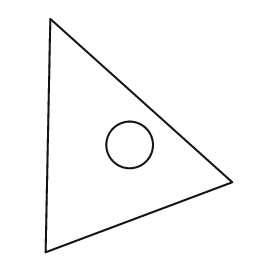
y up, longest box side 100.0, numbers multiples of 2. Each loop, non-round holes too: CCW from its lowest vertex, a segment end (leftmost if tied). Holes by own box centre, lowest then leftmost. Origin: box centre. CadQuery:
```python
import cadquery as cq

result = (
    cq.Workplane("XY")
    .moveTo(-40.0, -50.0)
    .lineTo(40.0, -20.0)
    .lineTo(-38.0, 50.0)
    .close()
    .moveTo(-4.0, -4.0)
    .circle(10.0)
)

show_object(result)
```